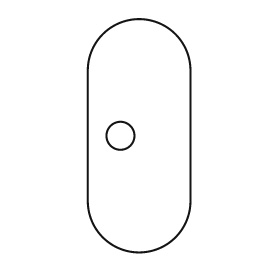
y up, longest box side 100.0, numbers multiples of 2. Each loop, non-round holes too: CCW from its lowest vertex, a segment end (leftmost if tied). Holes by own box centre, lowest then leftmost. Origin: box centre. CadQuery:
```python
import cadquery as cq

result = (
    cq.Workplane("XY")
    .moveTo(-22.0, -28.0)
    .threePointArc((0.0, -50.0), (22.0, -28.0))
    .lineTo(22.0, 28.0)
    .threePointArc((0.0, 50.0), (-22.0, 28.0))
    .close()
    .moveTo(-8.0, 0.0)
    .circle(6.0)
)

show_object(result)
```